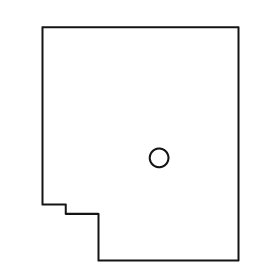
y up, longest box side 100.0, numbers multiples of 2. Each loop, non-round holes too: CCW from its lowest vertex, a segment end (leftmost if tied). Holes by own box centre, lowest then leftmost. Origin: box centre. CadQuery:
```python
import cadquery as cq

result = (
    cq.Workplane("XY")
    .moveTo(-18.0, -50.0)
    .lineTo(42.0, -50.0)
    .lineTo(42.0, 50.0)
    .lineTo(-42.0, 50.0)
    .lineTo(-42.0, -26.0)
    .lineTo(-32.0, -26.0)
    .lineTo(-32.0, -30.0)
    .lineTo(-18.0, -30.0)
    .close()
    .moveTo(8.0, -6.0)
    .circle(4.0)
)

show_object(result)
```